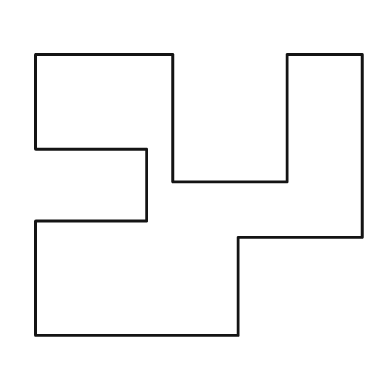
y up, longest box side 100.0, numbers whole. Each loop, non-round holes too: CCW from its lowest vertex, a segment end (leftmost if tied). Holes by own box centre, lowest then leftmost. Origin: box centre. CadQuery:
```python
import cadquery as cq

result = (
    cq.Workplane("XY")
    .moveTo(-50.0, -43.0)
    .lineTo(12.0, -43.0)
    .lineTo(12.0, -13.0)
    .lineTo(50.0, -13.0)
    .lineTo(50.0, 43.0)
    .lineTo(27.0, 43.0)
    .lineTo(27.0, 4.0)
    .lineTo(-8.0, 4.0)
    .lineTo(-8.0, 43.0)
    .lineTo(-50.0, 43.0)
    .lineTo(-50.0, 14.0)
    .lineTo(-16.0, 14.0)
    .lineTo(-16.0, -8.0)
    .lineTo(-50.0, -8.0)
    .close()
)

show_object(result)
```